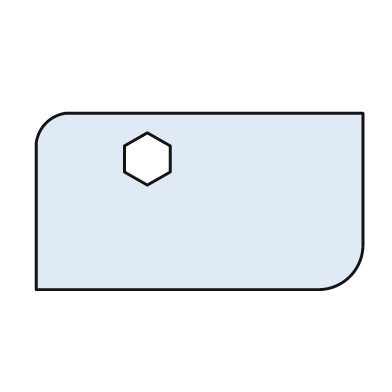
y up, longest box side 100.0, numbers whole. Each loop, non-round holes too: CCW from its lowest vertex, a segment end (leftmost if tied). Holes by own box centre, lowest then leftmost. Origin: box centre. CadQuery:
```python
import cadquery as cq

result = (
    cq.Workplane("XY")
    .moveTo(-50.0, -27.0)
    .lineTo(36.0, -27.0)
    .threePointArc((46.0, -23.0), (50.0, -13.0))
    .lineTo(50.0, 27.0)
    .lineTo(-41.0, 27.0)
    .threePointArc((-47.0, 24.0), (-50.0, 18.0))
    .close()
    .moveTo(-16.0, 5.0)
    .lineTo(-9.0, 9.0)
    .lineTo(-9.0, 17.0)
    .lineTo(-16.0, 21.0)
    .lineTo(-23.0, 17.0)
    .lineTo(-23.0, 9.0)
    .close()
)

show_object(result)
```